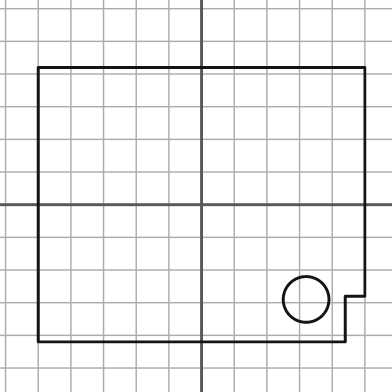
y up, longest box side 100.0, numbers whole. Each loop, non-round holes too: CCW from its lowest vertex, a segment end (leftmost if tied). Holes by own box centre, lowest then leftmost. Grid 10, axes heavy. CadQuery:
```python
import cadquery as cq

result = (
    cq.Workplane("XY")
    .moveTo(-50.0, -42.0)
    .lineTo(44.0, -42.0)
    .lineTo(44.0, -28.0)
    .lineTo(50.0, -28.0)
    .lineTo(50.0, 42.0)
    .lineTo(-50.0, 42.0)
    .close()
    .moveTo(32.0, -29.0)
    .circle(7.0)
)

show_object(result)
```